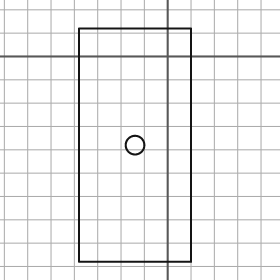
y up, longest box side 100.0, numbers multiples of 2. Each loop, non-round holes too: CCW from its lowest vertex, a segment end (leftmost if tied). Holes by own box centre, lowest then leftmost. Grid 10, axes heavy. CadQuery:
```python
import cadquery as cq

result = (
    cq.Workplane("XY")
    .moveTo(-38.0, -88.0)
    .lineTo(10.0, -88.0)
    .lineTo(10.0, 12.0)
    .lineTo(-38.0, 12.0)
    .close()
    .moveTo(-14.0, -38.0)
    .circle(4.0)
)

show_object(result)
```